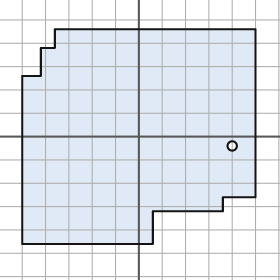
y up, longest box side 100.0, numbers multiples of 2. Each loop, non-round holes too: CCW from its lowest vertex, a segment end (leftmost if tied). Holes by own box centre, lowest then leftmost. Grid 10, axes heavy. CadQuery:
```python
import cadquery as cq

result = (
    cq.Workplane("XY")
    .moveTo(-50.0, -46.0)
    .lineTo(6.0, -46.0)
    .lineTo(6.0, -32.0)
    .lineTo(36.0, -32.0)
    .lineTo(36.0, -26.0)
    .lineTo(50.0, -26.0)
    .lineTo(50.0, 46.0)
    .lineTo(-36.0, 46.0)
    .lineTo(-36.0, 38.0)
    .lineTo(-42.0, 38.0)
    .lineTo(-42.0, 26.0)
    .lineTo(-50.0, 26.0)
    .close()
    .moveTo(40.0, -4.0)
    .circle(2.0)
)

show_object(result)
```